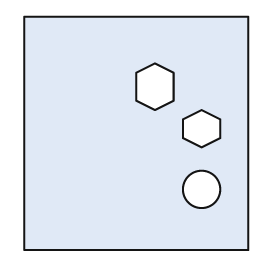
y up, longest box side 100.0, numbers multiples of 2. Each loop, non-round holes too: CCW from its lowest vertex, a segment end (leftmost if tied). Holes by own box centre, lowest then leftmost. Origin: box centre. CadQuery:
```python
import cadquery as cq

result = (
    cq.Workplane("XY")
    .moveTo(-48.0, -50.0)
    .lineTo(48.0, -50.0)
    .lineTo(48.0, 50.0)
    .lineTo(-48.0, 50.0)
    .close()
    .moveTo(28.0, -24.0)
    .circle(8.0)
    .moveTo(28.0, -6.0)
    .lineTo(36.0, -2.0)
    .lineTo(36.0, 6.0)
    .lineTo(28.0, 10.0)
    .lineTo(20.0, 6.0)
    .lineTo(20.0, -2.0)
    .close()
    .moveTo(8.0, 10.0)
    .lineTo(16.0, 14.0)
    .lineTo(16.0, 26.0)
    .lineTo(8.0, 30.0)
    .lineTo(0.0, 26.0)
    .lineTo(0.0, 14.0)
    .close()
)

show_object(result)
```